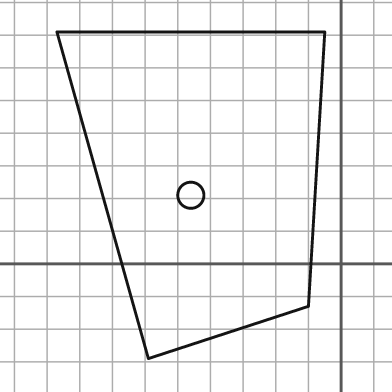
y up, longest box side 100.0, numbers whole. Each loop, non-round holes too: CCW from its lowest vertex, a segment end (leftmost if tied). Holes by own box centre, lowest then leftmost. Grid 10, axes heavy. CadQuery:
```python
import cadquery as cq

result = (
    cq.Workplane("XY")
    .moveTo(-59.0, -29.0)
    .lineTo(-10.0, -13.0)
    .lineTo(-5.0, 71.0)
    .lineTo(-87.0, 71.0)
    .close()
    .moveTo(-46.0, 21.0)
    .circle(4.0)
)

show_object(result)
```